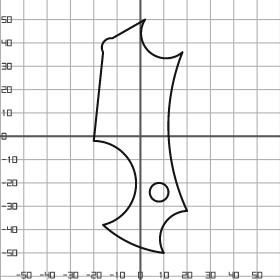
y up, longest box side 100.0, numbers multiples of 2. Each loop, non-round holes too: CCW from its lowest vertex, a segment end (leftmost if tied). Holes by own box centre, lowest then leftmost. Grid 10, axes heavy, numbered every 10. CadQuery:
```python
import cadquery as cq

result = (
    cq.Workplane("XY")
    .moveTo(10.0, -50.0)
    .threePointArc((10.0, -38.0), (20.0, -32.0))
    .threePointArc((12.0, 2.0), (18.0, 36.0))
    .threePointArc((4.0, 36.0), (2.0, 50.0))
    .lineTo(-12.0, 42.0)
    .threePointArc((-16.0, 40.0), (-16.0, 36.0))
    .lineTo(-20.0, -2.0)
    .threePointArc((-2.0, -18.0), (-16.0, -38.0))
    .threePointArc((-4.0, -46.0), (10.0, -50.0))
    .close()
    .moveTo(8.0, -24.0)
    .circle(4.0)
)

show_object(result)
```